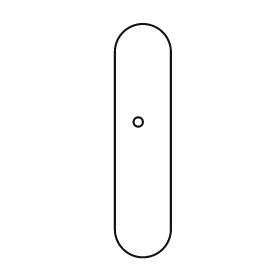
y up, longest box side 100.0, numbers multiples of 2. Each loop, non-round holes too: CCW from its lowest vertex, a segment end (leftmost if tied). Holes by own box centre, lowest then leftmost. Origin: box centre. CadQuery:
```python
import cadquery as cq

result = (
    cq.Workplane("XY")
    .moveTo(-12.0, -38.0)
    .threePointArc((0.0, -50.0), (12.0, -38.0))
    .lineTo(12.0, 38.0)
    .threePointArc((0.0, 50.0), (-12.0, 38.0))
    .close()
    .moveTo(-2.0, 8.0)
    .circle(2.0)
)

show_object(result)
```